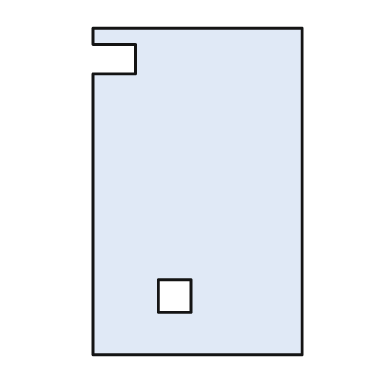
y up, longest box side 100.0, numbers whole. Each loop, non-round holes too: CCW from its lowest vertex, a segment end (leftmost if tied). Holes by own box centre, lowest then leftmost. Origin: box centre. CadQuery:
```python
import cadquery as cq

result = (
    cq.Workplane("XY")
    .moveTo(-32.0, -50.0)
    .lineTo(32.0, -50.0)
    .lineTo(32.0, 50.0)
    .lineTo(-32.0, 50.0)
    .lineTo(-32.0, 45.0)
    .lineTo(-19.0, 45.0)
    .lineTo(-19.0, 36.0)
    .lineTo(-32.0, 36.0)
    .close()
    .moveTo(-12.0, -37.0)
    .lineTo(-2.0, -37.0)
    .lineTo(-2.0, -27.0)
    .lineTo(-12.0, -27.0)
    .close()
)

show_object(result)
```